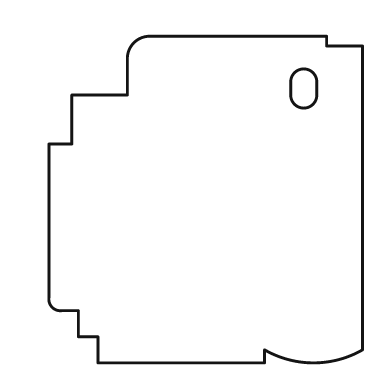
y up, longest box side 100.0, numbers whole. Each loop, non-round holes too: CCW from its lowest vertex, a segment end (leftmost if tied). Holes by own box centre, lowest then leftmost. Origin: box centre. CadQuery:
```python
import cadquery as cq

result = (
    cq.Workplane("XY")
    .moveTo(-33.0, -50.0)
    .lineTo(18.0, -50.0)
    .lineTo(18.0, -46.0)
    .threePointArc((33.0, -50.0), (48.0, -46.0))
    .lineTo(48.0, 47.0)
    .lineTo(37.0, 47.0)
    .lineTo(37.0, 50.0)
    .lineTo(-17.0, 50.0)
    .threePointArc((-22.0, 48.0), (-24.0, 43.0))
    .lineTo(-24.0, 32.0)
    .lineTo(-41.0, 32.0)
    .lineTo(-41.0, 17.0)
    .lineTo(-48.0, 17.0)
    .lineTo(-48.0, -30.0)
    .threePointArc((-47.0, -33.0), (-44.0, -34.0))
    .lineTo(-39.0, -34.0)
    .lineTo(-39.0, -42.0)
    .lineTo(-33.0, -42.0)
    .close()
    .moveTo(26.0, 32.0)
    .threePointArc((30.0, 28.0), (34.0, 32.0))
    .lineTo(34.0, 36.0)
    .threePointArc((30.0, 40.0), (26.0, 36.0))
    .close()
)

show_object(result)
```